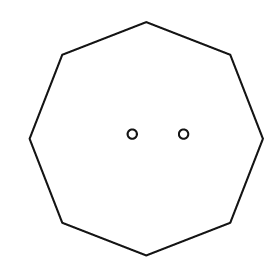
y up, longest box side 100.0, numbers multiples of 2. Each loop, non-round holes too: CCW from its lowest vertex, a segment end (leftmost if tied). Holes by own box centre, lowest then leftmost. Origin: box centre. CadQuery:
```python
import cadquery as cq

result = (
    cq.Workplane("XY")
    .moveTo(0.0, -50.0)
    .lineTo(36.0, -36.0)
    .lineTo(50.0, 0.0)
    .lineTo(36.0, 36.0)
    .lineTo(0.0, 50.0)
    .lineTo(-36.0, 36.0)
    .lineTo(-50.0, 0.0)
    .lineTo(-36.0, -36.0)
    .close()
    .moveTo(-6.0, 2.0)
    .circle(2.0)
    .moveTo(16.0, 2.0)
    .circle(2.0)
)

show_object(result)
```